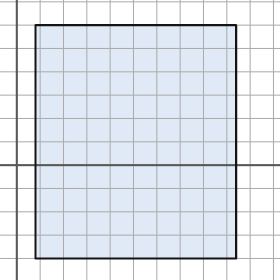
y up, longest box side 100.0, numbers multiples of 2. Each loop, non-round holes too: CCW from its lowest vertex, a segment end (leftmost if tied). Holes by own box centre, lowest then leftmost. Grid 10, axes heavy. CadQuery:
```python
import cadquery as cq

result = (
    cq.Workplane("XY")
    .moveTo(8.0, -40.0)
    .lineTo(94.0, -40.0)
    .lineTo(94.0, 60.0)
    .lineTo(8.0, 60.0)
    .close()
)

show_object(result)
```